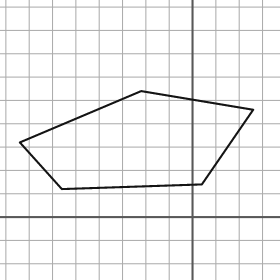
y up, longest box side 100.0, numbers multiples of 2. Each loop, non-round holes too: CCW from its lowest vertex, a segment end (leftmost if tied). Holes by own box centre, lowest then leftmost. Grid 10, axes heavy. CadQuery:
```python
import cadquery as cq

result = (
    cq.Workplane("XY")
    .moveTo(-56.0, 12.0)
    .lineTo(4.0, 14.0)
    .lineTo(26.0, 46.0)
    .lineTo(-22.0, 54.0)
    .lineTo(-74.0, 32.0)
    .close()
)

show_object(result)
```